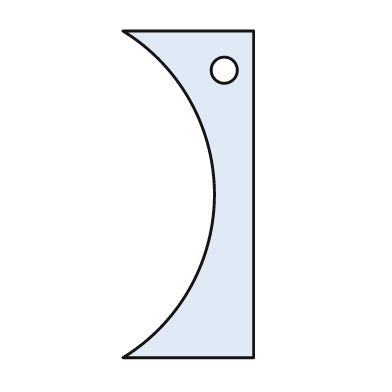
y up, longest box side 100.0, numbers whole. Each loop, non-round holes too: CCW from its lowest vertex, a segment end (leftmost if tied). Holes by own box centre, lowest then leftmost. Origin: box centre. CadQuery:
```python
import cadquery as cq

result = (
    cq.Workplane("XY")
    .moveTo(-20.0, -50.0)
    .lineTo(20.0, -50.0)
    .lineTo(20.0, 50.0)
    .lineTo(-20.0, 50.0)
    .threePointArc((8.0, 0.0), (-20.0, -50.0))
    .close()
    .moveTo(11.0, 38.0)
    .circle(4.0)
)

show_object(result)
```